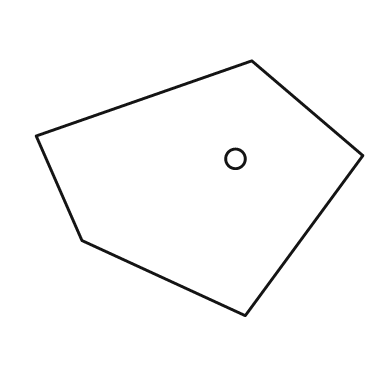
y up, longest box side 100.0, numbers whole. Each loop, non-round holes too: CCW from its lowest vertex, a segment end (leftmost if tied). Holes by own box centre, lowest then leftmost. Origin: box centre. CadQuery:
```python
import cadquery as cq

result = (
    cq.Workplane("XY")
    .moveTo(14.0, -39.0)
    .lineTo(50.0, 10.0)
    .lineTo(16.0, 39.0)
    .lineTo(-50.0, 16.0)
    .lineTo(-36.0, -16.0)
    .close()
    .moveTo(11.0, 9.0)
    .circle(3.0)
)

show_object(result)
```